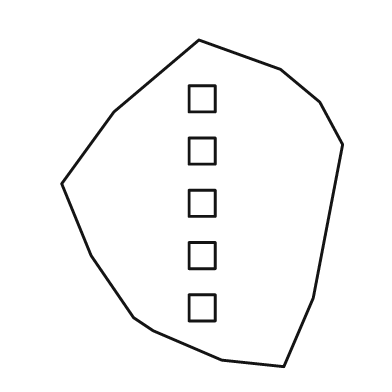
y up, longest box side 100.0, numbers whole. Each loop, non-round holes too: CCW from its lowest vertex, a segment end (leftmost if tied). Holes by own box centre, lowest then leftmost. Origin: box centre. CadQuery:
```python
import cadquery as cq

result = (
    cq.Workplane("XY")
    .moveTo(25.0, -50.0)
    .lineTo(34.0, -29.0)
    .lineTo(43.0, 18.0)
    .lineTo(36.0, 31.0)
    .lineTo(24.0, 41.0)
    .lineTo(-1.0, 50.0)
    .lineTo(-27.0, 28.0)
    .lineTo(-43.0, 6.0)
    .lineTo(-34.0, -16.0)
    .lineTo(-21.0, -35.0)
    .lineTo(-15.0, -39.0)
    .lineTo(6.0, -48.0)
    .close()
    .moveTo(-4.0, -36.0)
    .lineTo(4.0, -36.0)
    .lineTo(4.0, -28.0)
    .lineTo(-4.0, -28.0)
    .close()
    .moveTo(-4.0, -20.0)
    .lineTo(4.0, -20.0)
    .lineTo(4.0, -12.0)
    .lineTo(-4.0, -12.0)
    .close()
    .moveTo(-4.0, -4.0)
    .lineTo(4.0, -4.0)
    .lineTo(4.0, 4.0)
    .lineTo(-4.0, 4.0)
    .close()
    .moveTo(-4.0, 12.0)
    .lineTo(4.0, 12.0)
    .lineTo(4.0, 20.0)
    .lineTo(-4.0, 20.0)
    .close()
    .moveTo(-4.0, 28.0)
    .lineTo(4.0, 28.0)
    .lineTo(4.0, 36.0)
    .lineTo(-4.0, 36.0)
    .close()
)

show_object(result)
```